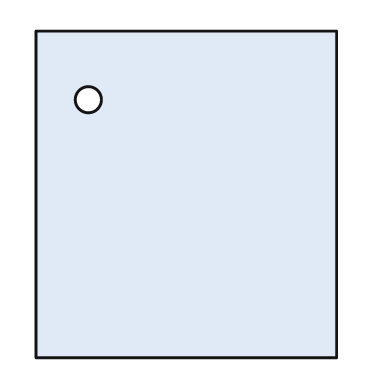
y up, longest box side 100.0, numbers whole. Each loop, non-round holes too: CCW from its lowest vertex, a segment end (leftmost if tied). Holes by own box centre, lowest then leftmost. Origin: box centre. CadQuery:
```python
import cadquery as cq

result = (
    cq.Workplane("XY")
    .moveTo(-46.0, -50.0)
    .lineTo(46.0, -50.0)
    .lineTo(46.0, 50.0)
    .lineTo(-46.0, 50.0)
    .close()
    .moveTo(-30.0, 29.0)
    .circle(4.0)
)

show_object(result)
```